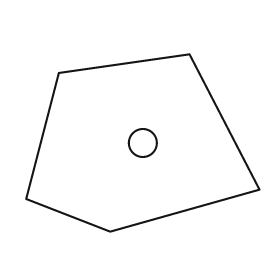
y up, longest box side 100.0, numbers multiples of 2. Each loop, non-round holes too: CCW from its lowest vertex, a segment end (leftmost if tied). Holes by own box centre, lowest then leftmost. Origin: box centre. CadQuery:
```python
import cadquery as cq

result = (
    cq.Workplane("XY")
    .moveTo(-14.0, -38.0)
    .lineTo(50.0, -20.0)
    .lineTo(20.0, 38.0)
    .lineTo(-36.0, 30.0)
    .lineTo(-50.0, -24.0)
    .close()
    .moveTo(0.0, 0.0)
    .circle(6.0)
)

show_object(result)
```